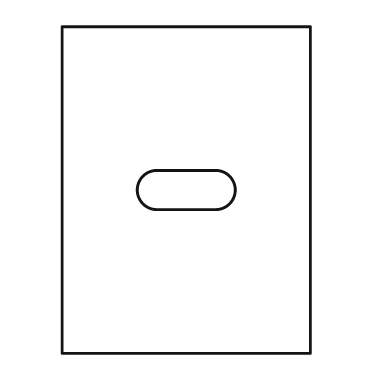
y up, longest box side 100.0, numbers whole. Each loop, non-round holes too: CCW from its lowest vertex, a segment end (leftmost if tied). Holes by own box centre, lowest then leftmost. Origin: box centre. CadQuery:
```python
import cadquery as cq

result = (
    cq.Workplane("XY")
    .moveTo(-38.0, -50.0)
    .lineTo(38.0, -50.0)
    .lineTo(38.0, 50.0)
    .lineTo(-38.0, 50.0)
    .close()
    .moveTo(-9.0, -6.0)
    .lineTo(9.0, -6.0)
    .threePointArc((15.0, 0.0), (9.0, 6.0))
    .lineTo(-9.0, 6.0)
    .threePointArc((-15.0, 0.0), (-9.0, -6.0))
    .close()
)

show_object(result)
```